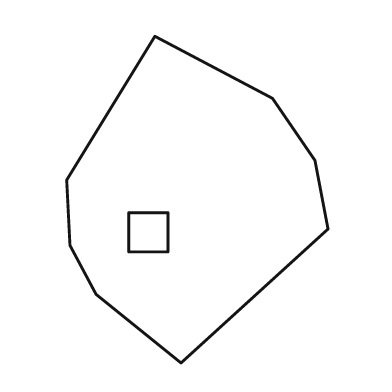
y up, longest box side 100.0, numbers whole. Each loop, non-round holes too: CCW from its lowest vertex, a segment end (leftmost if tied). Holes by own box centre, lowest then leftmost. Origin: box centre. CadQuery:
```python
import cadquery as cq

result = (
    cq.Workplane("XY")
    .moveTo(-5.0, -50.0)
    .lineTo(40.0, -9.0)
    .lineTo(36.0, 12.0)
    .lineTo(23.0, 31.0)
    .lineTo(-13.0, 50.0)
    .lineTo(-40.0, 6.0)
    .lineTo(-39.0, -14.0)
    .lineTo(-31.0, -29.0)
    .close()
    .moveTo(-21.0, -16.0)
    .lineTo(-9.0, -16.0)
    .lineTo(-9.0, -4.0)
    .lineTo(-21.0, -4.0)
    .close()
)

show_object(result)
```